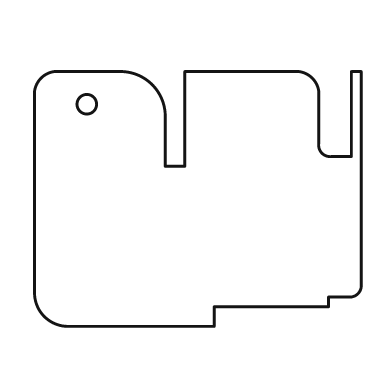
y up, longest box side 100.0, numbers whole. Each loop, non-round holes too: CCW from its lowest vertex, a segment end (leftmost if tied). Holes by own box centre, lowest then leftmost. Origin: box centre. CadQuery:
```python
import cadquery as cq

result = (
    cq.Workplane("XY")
    .moveTo(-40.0, -39.0)
    .lineTo(5.0, -39.0)
    .lineTo(5.0, -33.0)
    .lineTo(40.0, -33.0)
    .lineTo(40.0, -30.0)
    .lineTo(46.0, -30.0)
    .threePointArc((49.0, -29.0), (50.0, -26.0))
    .lineTo(50.0, 39.0)
    .lineTo(47.0, 39.0)
    .lineTo(47.0, 13.0)
    .lineTo(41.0, 13.0)
    .threePointArc((38.0, 14.0), (37.0, 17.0))
    .lineTo(37.0, 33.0)
    .threePointArc((35.0, 37.0), (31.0, 39.0))
    .lineTo(-4.0, 39.0)
    .lineTo(-4.0, 10.0)
    .lineTo(-10.0, 10.0)
    .lineTo(-10.0, 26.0)
    .threePointArc((-14.0, 35.0), (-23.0, 39.0))
    .lineTo(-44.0, 39.0)
    .threePointArc((-48.0, 37.0), (-50.0, 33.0))
    .lineTo(-50.0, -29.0)
    .threePointArc((-47.0, -36.0), (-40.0, -39.0))
    .close()
    .moveTo(-34.0, 29.0)
    .circle(3.0)
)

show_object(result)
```